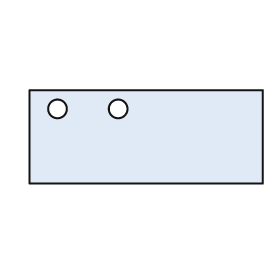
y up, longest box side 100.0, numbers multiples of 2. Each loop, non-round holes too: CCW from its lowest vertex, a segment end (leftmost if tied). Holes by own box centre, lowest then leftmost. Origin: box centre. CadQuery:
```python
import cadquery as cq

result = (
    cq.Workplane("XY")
    .moveTo(-50.0, -20.0)
    .lineTo(50.0, -20.0)
    .lineTo(50.0, 20.0)
    .lineTo(-50.0, 20.0)
    .close()
    .moveTo(-38.0, 12.0)
    .circle(4.0)
    .moveTo(-12.0, 12.0)
    .circle(4.0)
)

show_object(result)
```